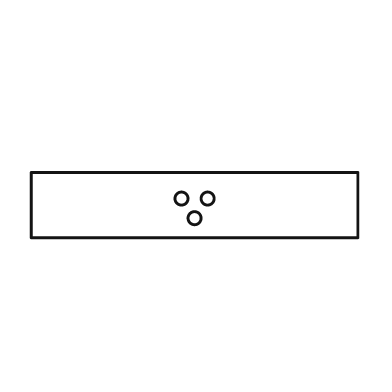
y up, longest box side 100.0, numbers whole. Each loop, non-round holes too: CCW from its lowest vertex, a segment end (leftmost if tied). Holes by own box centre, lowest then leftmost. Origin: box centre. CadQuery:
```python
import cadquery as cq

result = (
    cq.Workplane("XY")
    .moveTo(-50.0, -10.0)
    .lineTo(50.0, -10.0)
    .lineTo(50.0, 10.0)
    .lineTo(-50.0, 10.0)
    .close()
    .moveTo(0.0, -4.0)
    .circle(2.0)
    .moveTo(-4.0, 2.0)
    .circle(2.0)
    .moveTo(4.0, 2.0)
    .circle(2.0)
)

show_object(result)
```